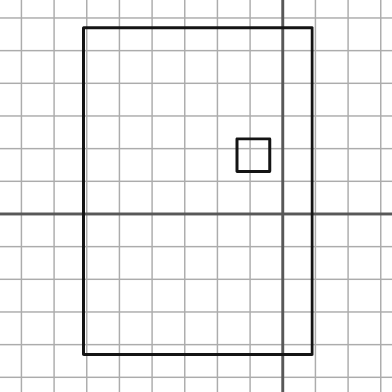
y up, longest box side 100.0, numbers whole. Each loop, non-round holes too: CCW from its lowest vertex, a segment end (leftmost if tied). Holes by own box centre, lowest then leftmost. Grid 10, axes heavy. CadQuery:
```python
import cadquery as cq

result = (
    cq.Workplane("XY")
    .moveTo(-61.0, -43.0)
    .lineTo(9.0, -43.0)
    .lineTo(9.0, 57.0)
    .lineTo(-61.0, 57.0)
    .close()
    .moveTo(-14.0, 13.0)
    .lineTo(-4.0, 13.0)
    .lineTo(-4.0, 23.0)
    .lineTo(-14.0, 23.0)
    .close()
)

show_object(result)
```